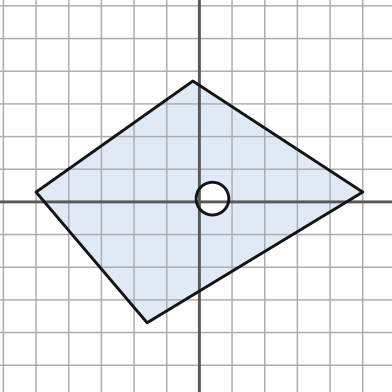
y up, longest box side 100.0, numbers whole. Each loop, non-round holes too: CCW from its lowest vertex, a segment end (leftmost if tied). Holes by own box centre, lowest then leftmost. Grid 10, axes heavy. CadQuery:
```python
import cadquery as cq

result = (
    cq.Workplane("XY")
    .moveTo(-16.0, -37.0)
    .lineTo(50.0, 3.0)
    .lineTo(-2.0, 37.0)
    .lineTo(-50.0, 3.0)
    .close()
    .moveTo(4.0, 1.0)
    .circle(5.0)
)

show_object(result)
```